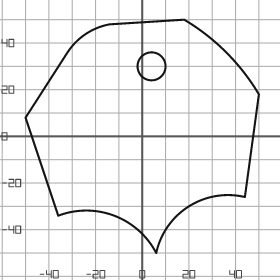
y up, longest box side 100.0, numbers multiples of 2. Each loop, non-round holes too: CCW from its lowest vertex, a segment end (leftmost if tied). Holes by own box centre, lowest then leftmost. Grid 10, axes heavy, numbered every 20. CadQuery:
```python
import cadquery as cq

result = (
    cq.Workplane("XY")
    .moveTo(6.0, -50.0)
    .threePointArc((20.0, -30.0), (44.0, -26.0))
    .lineTo(50.0, 18.0)
    .threePointArc((36.0, 36.0), (18.0, 50.0))
    .lineTo(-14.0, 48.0)
    .threePointArc((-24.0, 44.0), (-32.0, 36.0))
    .lineTo(-50.0, 8.0)
    .lineTo(-36.0, -34.0)
    .threePointArc((-12.0, -34.0), (6.0, -50.0))
    .close()
    .moveTo(4.0, 30.0)
    .circle(6.0)
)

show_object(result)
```